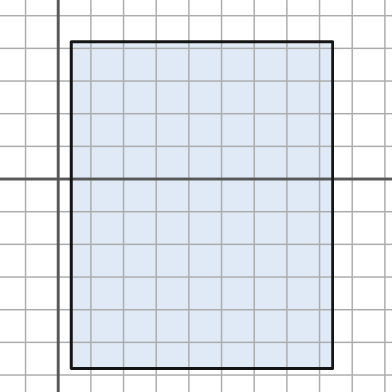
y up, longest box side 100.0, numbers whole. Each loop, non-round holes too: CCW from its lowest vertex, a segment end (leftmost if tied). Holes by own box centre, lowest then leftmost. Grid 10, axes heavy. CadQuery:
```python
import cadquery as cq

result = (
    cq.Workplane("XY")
    .moveTo(4.0, -58.0)
    .lineTo(84.0, -58.0)
    .lineTo(84.0, 42.0)
    .lineTo(4.0, 42.0)
    .close()
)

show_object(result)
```